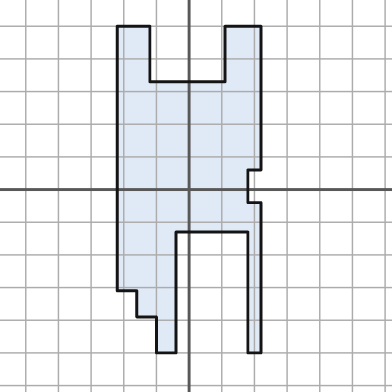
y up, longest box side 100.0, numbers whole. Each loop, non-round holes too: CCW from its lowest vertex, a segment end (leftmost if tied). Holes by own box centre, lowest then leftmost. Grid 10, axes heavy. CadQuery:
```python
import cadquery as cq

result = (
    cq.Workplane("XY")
    .moveTo(-10.0, -50.0)
    .lineTo(-4.0, -50.0)
    .lineTo(-4.0, -13.0)
    .lineTo(18.0, -13.0)
    .lineTo(18.0, -50.0)
    .lineTo(22.0, -50.0)
    .lineTo(22.0, -4.0)
    .lineTo(18.0, -4.0)
    .lineTo(18.0, 6.0)
    .lineTo(22.0, 6.0)
    .lineTo(22.0, 50.0)
    .lineTo(11.0, 50.0)
    .lineTo(11.0, 33.0)
    .lineTo(-12.0, 33.0)
    .lineTo(-12.0, 50.0)
    .lineTo(-22.0, 50.0)
    .lineTo(-22.0, -31.0)
    .lineTo(-16.0, -31.0)
    .lineTo(-16.0, -39.0)
    .lineTo(-10.0, -39.0)
    .close()
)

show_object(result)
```